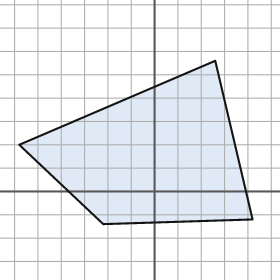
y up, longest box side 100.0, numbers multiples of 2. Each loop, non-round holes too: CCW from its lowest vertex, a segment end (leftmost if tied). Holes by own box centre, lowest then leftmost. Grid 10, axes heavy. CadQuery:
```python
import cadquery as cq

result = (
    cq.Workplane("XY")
    .moveTo(-22.0, -14.0)
    .lineTo(42.0, -12.0)
    .lineTo(26.0, 56.0)
    .lineTo(-58.0, 20.0)
    .close()
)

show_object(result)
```